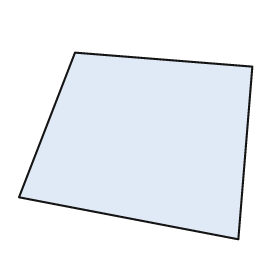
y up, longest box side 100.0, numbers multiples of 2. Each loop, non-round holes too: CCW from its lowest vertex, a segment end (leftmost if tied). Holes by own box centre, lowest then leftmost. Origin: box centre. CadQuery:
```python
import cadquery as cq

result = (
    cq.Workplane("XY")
    .moveTo(44.0, -40.0)
    .lineTo(50.0, 34.0)
    .lineTo(-26.0, 40.0)
    .lineTo(-50.0, -22.0)
    .close()
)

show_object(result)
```